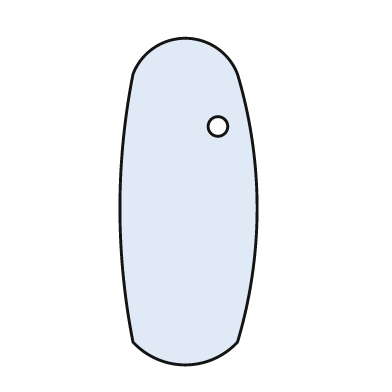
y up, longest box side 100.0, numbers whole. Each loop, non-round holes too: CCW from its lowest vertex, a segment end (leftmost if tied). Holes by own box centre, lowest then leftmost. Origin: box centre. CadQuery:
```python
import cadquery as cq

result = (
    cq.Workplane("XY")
    .moveTo(-17.0, -43.0)
    .threePointArc((-1.0, -50.0), (15.0, -43.0))
    .threePointArc((21.0, -2.0), (15.0, 39.0))
    .threePointArc((-1.0, 50.0), (-17.0, 39.0))
    .threePointArc((-21.0, -2.0), (-17.0, -43.0))
    .close()
    .moveTo(9.0, 23.0)
    .circle(3.0)
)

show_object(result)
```